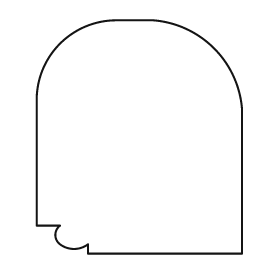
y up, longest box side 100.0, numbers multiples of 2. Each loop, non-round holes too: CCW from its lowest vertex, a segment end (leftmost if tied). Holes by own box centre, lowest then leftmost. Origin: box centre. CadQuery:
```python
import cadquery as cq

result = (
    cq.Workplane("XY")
    .moveTo(-22.0, -50.0)
    .lineTo(44.0, -50.0)
    .lineTo(44.0, 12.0)
    .threePointArc((32.0, 38.0), (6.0, 50.0))
    .lineTo(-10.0, 50.0)
    .threePointArc((-34.0, 40.0), (-44.0, 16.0))
    .lineTo(-44.0, -38.0)
    .lineTo(-34.0, -38.0)
    .threePointArc((-36.0, -42.0), (-34.0, -46.0))
    .threePointArc((-28.0, -48.0), (-22.0, -46.0))
    .close()
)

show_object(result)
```